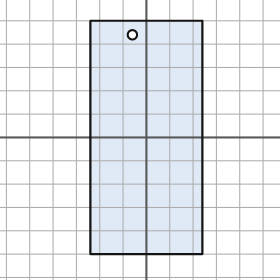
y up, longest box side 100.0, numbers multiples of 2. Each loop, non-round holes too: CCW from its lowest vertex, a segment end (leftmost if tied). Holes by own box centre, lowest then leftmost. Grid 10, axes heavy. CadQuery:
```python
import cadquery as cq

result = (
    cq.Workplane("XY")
    .moveTo(-24.0, -50.0)
    .lineTo(24.0, -50.0)
    .lineTo(24.0, 50.0)
    .lineTo(-24.0, 50.0)
    .close()
    .moveTo(-6.0, 44.0)
    .circle(2.0)
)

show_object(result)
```